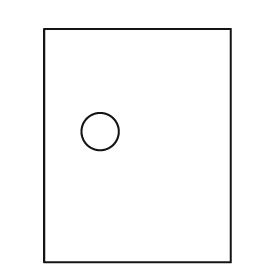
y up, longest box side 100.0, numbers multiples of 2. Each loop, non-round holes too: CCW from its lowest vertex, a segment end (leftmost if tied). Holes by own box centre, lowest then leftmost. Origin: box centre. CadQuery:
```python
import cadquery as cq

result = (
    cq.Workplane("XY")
    .moveTo(-40.0, -50.0)
    .lineTo(40.0, -50.0)
    .lineTo(40.0, 50.0)
    .lineTo(-40.0, 50.0)
    .close()
    .moveTo(-16.0, 6.0)
    .circle(8.0)
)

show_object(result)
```